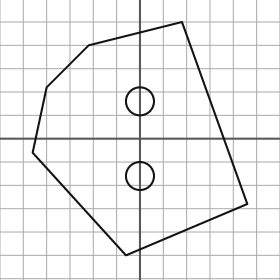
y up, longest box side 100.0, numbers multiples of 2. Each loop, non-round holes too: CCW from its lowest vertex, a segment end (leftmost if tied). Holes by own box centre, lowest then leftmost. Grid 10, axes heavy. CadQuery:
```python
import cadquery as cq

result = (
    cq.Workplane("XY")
    .moveTo(-6.0, -50.0)
    .lineTo(46.0, -28.0)
    .lineTo(18.0, 50.0)
    .lineTo(-22.0, 40.0)
    .lineTo(-40.0, 22.0)
    .lineTo(-46.0, -6.0)
    .close()
    .moveTo(0.0, -16.0)
    .circle(6.0)
    .moveTo(0.0, 16.0)
    .circle(6.0)
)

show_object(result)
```